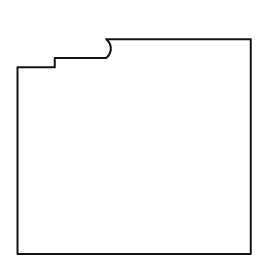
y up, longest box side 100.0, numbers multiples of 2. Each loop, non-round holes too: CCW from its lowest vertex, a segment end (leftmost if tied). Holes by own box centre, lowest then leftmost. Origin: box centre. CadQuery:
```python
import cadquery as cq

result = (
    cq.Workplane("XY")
    .moveTo(-50.0, -46.0)
    .lineTo(50.0, -46.0)
    .lineTo(50.0, 46.0)
    .lineTo(-12.0, 46.0)
    .threePointArc((-10.0, 42.0), (-12.0, 38.0))
    .lineTo(-34.0, 38.0)
    .lineTo(-34.0, 34.0)
    .lineTo(-50.0, 34.0)
    .close()
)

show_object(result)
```